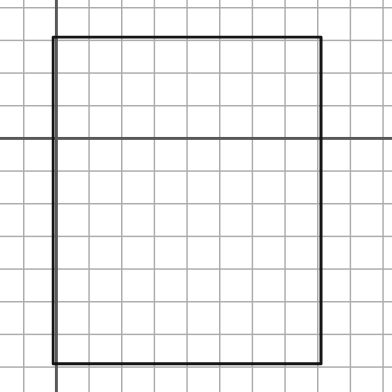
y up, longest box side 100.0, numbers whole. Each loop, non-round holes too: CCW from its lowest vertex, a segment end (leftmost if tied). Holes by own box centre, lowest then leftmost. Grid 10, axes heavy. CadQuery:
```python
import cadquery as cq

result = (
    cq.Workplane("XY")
    .moveTo(-1.0, -69.0)
    .lineTo(81.0, -69.0)
    .lineTo(81.0, 31.0)
    .lineTo(-1.0, 31.0)
    .close()
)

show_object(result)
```